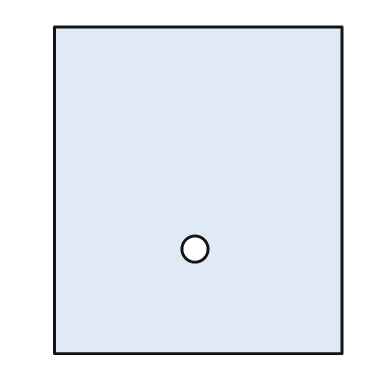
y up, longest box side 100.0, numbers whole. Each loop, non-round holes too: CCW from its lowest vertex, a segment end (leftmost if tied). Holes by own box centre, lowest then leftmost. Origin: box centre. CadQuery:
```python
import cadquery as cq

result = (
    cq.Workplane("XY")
    .moveTo(-44.0, -50.0)
    .lineTo(44.0, -50.0)
    .lineTo(44.0, 50.0)
    .lineTo(-44.0, 50.0)
    .close()
    .moveTo(-1.0, -18.0)
    .circle(4.0)
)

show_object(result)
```